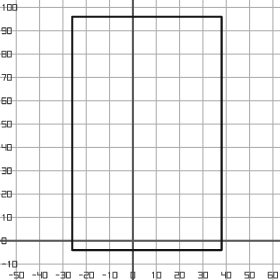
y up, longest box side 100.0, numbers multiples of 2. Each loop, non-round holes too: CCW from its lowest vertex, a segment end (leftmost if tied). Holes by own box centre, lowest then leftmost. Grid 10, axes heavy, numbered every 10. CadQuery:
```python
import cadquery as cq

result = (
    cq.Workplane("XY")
    .moveTo(-26.0, -4.0)
    .lineTo(38.0, -4.0)
    .lineTo(38.0, 96.0)
    .lineTo(-26.0, 96.0)
    .close()
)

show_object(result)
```